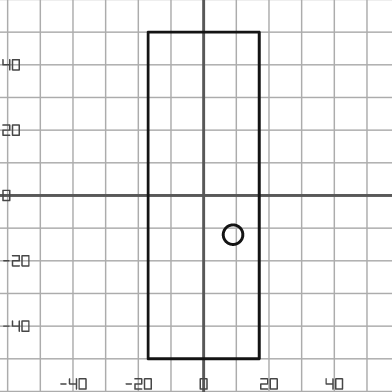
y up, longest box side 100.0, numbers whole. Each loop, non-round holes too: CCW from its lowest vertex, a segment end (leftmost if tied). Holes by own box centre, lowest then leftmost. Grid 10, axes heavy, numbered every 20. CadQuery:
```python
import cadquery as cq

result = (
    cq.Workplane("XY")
    .moveTo(-17.0, -50.0)
    .lineTo(17.0, -50.0)
    .lineTo(17.0, 50.0)
    .lineTo(-17.0, 50.0)
    .close()
    .moveTo(9.0, -12.0)
    .circle(3.0)
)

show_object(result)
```